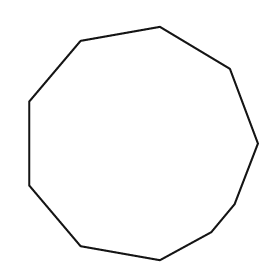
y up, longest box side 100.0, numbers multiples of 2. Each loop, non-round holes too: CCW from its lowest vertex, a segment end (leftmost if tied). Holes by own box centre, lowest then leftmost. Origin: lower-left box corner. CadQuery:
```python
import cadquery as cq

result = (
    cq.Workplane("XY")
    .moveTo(56.0, 0.0)
    .lineTo(78.0, 12.0)
    .lineTo(88.0, 24.0)
    .lineTo(98.0, 50.0)
    .lineTo(86.0, 82.0)
    .lineTo(56.0, 100.0)
    .lineTo(22.0, 94.0)
    .lineTo(0.0, 68.0)
    .lineTo(0.0, 32.0)
    .lineTo(22.0, 6.0)
    .close()
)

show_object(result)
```